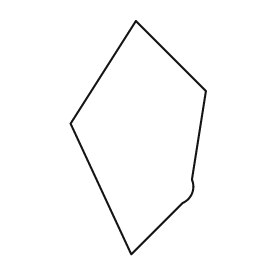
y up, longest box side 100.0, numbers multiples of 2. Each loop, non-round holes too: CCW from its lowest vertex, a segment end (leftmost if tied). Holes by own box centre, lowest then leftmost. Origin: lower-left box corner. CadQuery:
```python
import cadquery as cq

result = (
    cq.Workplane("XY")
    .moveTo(26.0, 0.0)
    .lineTo(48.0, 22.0)
    .threePointArc((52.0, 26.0), (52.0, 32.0))
    .lineTo(58.0, 70.0)
    .lineTo(28.0, 100.0)
    .lineTo(0.0, 56.0)
    .close()
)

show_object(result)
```